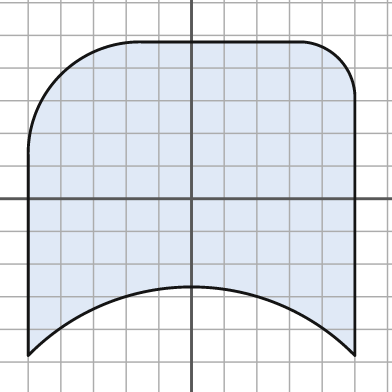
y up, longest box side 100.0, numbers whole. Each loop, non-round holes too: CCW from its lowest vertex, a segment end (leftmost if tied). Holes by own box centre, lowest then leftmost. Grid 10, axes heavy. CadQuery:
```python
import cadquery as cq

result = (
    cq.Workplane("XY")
    .moveTo(-50.0, -48.0)
    .threePointArc((0.0, -27.0), (50.0, -48.0))
    .lineTo(50.0, 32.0)
    .threePointArc((45.0, 43.0), (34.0, 48.0))
    .lineTo(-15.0, 48.0)
    .threePointArc((-40.0, 38.0), (-50.0, 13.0))
    .close()
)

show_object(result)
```